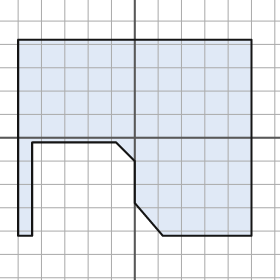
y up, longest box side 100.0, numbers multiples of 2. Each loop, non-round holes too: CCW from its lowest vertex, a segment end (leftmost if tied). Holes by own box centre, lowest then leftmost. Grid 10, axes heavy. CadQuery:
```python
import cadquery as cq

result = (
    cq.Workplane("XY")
    .moveTo(-50.0, -42.0)
    .lineTo(-44.0, -42.0)
    .lineTo(-44.0, -2.0)
    .lineTo(-8.0, -2.0)
    .lineTo(0.0, -10.0)
    .lineTo(0.0, -28.0)
    .lineTo(12.0, -42.0)
    .lineTo(50.0, -42.0)
    .lineTo(50.0, 42.0)
    .lineTo(-50.0, 42.0)
    .close()
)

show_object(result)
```